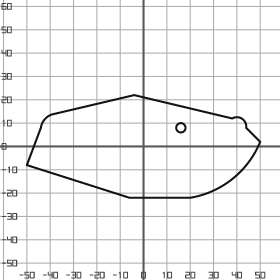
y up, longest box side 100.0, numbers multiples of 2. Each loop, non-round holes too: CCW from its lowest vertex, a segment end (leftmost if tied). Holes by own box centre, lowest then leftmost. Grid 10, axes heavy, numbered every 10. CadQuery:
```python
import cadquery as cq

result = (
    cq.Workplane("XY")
    .moveTo(-6.0, -22.0)
    .lineTo(20.0, -22.0)
    .threePointArc((38.0, -14.0), (50.0, 2.0))
    .lineTo(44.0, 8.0)
    .threePointArc((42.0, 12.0), (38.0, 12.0))
    .lineTo(-4.0, 22.0)
    .lineTo(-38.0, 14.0)
    .threePointArc((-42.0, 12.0), (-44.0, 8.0))
    .lineTo(-50.0, -8.0)
    .close()
    .moveTo(16.0, 8.0)
    .circle(2.0)
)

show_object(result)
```